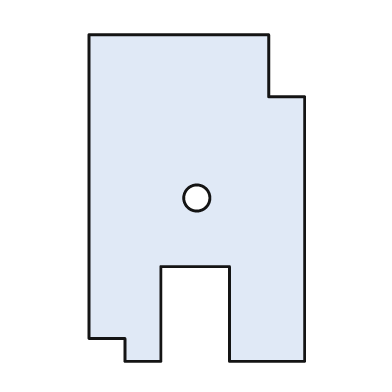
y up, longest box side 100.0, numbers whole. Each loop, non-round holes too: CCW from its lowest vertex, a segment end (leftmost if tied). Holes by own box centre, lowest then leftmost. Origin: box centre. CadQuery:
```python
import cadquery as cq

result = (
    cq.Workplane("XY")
    .moveTo(-22.0, -50.0)
    .lineTo(-11.0, -50.0)
    .lineTo(-11.0, -21.0)
    .lineTo(10.0, -21.0)
    .lineTo(10.0, -50.0)
    .lineTo(33.0, -50.0)
    .lineTo(33.0, 31.0)
    .lineTo(22.0, 31.0)
    .lineTo(22.0, 50.0)
    .lineTo(-33.0, 50.0)
    .lineTo(-33.0, -43.0)
    .lineTo(-22.0, -43.0)
    .close()
    .moveTo(0.0, 0.0)
    .circle(4.0)
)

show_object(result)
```